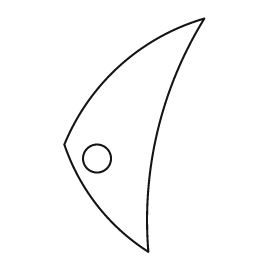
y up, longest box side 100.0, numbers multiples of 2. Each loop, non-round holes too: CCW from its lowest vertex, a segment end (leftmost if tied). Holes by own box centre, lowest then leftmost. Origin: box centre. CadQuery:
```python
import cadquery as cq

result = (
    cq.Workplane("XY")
    .moveTo(6.0, -50.0)
    .threePointArc((10.0, 2.0), (30.0, 50.0))
    .threePointArc((-6.0, 30.0), (-30.0, -4.0))
    .threePointArc((-16.0, -30.0), (6.0, -50.0))
    .close()
    .moveTo(-16.0, -10.0)
    .circle(6.0)
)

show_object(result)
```